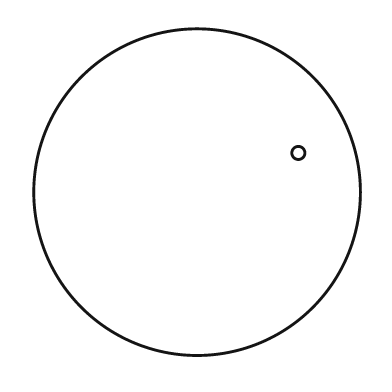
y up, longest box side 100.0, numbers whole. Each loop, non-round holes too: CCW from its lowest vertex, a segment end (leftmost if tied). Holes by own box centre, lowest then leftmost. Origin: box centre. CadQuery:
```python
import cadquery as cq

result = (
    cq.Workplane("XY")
    .moveTo(0.0, 0.0)
    .circle(50.0)
    .moveTo(31.0, 12.0)
    .circle(2.0)
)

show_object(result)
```